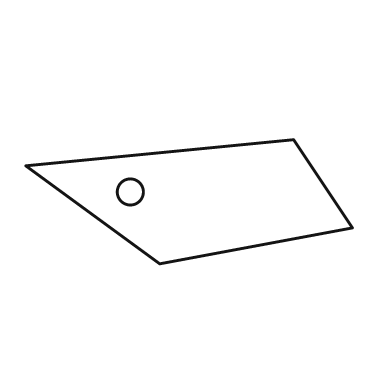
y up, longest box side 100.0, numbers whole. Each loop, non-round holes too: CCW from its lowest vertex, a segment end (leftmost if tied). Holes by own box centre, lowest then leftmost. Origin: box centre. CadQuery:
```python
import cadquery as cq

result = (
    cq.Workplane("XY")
    .moveTo(-9.0, -19.0)
    .lineTo(50.0, -8.0)
    .lineTo(32.0, 19.0)
    .lineTo(-50.0, 11.0)
    .close()
    .moveTo(-18.0, 3.0)
    .circle(4.0)
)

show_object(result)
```